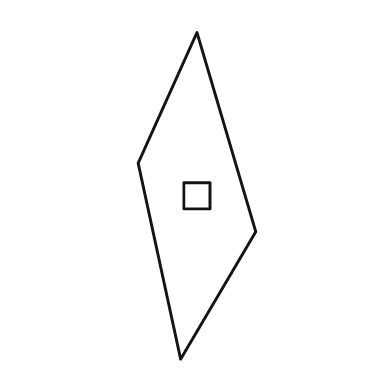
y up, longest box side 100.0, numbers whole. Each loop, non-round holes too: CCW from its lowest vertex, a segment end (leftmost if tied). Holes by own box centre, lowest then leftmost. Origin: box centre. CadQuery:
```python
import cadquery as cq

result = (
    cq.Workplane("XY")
    .moveTo(-5.0, -50.0)
    .lineTo(18.0, -11.0)
    .lineTo(0.0, 50.0)
    .lineTo(-18.0, 10.0)
    .close()
    .moveTo(-4.0, -4.0)
    .lineTo(4.0, -4.0)
    .lineTo(4.0, 4.0)
    .lineTo(-4.0, 4.0)
    .close()
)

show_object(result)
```